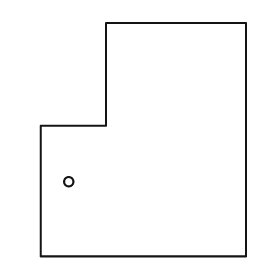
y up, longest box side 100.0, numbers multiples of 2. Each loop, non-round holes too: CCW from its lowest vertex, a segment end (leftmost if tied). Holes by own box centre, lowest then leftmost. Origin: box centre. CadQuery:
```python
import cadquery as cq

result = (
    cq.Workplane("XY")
    .moveTo(-44.0, -50.0)
    .lineTo(44.0, -50.0)
    .lineTo(44.0, 50.0)
    .lineTo(-16.0, 50.0)
    .lineTo(-16.0, 6.0)
    .lineTo(-44.0, 6.0)
    .close()
    .moveTo(-32.0, -18.0)
    .circle(2.0)
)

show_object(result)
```